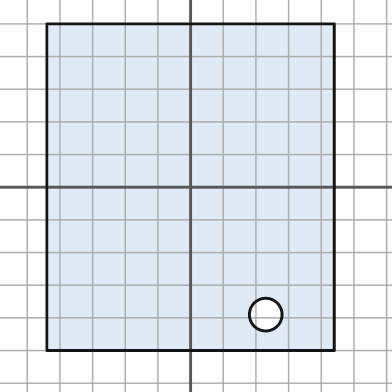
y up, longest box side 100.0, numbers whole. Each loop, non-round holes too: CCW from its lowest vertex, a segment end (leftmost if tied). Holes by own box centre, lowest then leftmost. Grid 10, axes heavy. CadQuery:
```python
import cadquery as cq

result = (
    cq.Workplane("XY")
    .moveTo(-44.0, -50.0)
    .lineTo(44.0, -50.0)
    .lineTo(44.0, 50.0)
    .lineTo(-44.0, 50.0)
    .close()
    .moveTo(23.0, -39.0)
    .circle(5.0)
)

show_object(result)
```